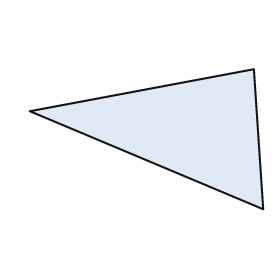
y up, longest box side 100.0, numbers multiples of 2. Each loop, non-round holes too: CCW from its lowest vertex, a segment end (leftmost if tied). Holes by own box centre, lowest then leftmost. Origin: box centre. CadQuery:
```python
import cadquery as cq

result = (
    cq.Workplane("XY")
    .moveTo(50.0, -30.0)
    .lineTo(46.0, 30.0)
    .lineTo(-50.0, 12.0)
    .close()
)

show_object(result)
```